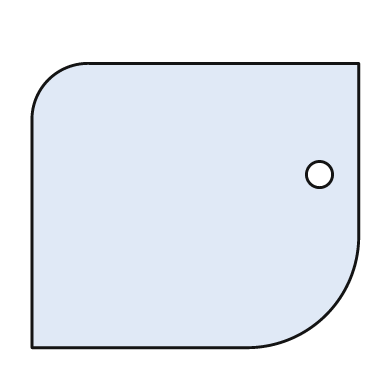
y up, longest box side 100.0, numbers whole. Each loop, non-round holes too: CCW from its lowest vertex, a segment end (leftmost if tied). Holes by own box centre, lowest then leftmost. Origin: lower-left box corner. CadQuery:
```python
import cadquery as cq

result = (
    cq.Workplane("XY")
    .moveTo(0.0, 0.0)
    .lineTo(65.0, 0.0)
    .threePointArc((90.0, 10.0), (100.0, 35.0))
    .lineTo(100.0, 87.0)
    .lineTo(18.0, 87.0)
    .threePointArc((5.0, 82.0), (0.0, 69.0))
    .close()
    .moveTo(88.0, 53.0)
    .circle(4.0)
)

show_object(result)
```